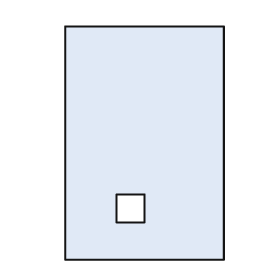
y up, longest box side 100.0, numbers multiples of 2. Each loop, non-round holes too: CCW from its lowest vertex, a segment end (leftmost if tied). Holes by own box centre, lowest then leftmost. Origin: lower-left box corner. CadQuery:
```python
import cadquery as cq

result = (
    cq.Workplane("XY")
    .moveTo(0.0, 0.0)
    .lineTo(68.0, 0.0)
    .lineTo(68.0, 100.0)
    .lineTo(0.0, 100.0)
    .close()
    .moveTo(22.0, 16.0)
    .lineTo(34.0, 16.0)
    .lineTo(34.0, 28.0)
    .lineTo(22.0, 28.0)
    .close()
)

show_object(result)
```